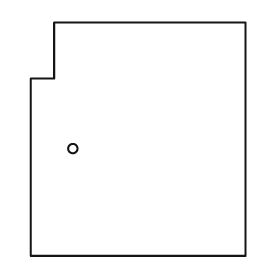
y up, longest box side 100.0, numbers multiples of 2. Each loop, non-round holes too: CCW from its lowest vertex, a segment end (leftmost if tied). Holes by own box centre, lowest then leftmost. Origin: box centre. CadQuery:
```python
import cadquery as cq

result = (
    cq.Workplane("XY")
    .moveTo(-46.0, -50.0)
    .lineTo(46.0, -50.0)
    .lineTo(46.0, 50.0)
    .lineTo(-36.0, 50.0)
    .lineTo(-36.0, 26.0)
    .lineTo(-46.0, 26.0)
    .close()
    .moveTo(-28.0, -4.0)
    .circle(2.0)
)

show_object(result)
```